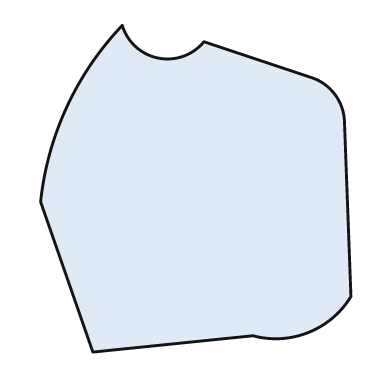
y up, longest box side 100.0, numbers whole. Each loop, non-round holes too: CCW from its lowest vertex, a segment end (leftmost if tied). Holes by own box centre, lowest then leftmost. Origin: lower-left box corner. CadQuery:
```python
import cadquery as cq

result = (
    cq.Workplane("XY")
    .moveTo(16.0, 0.0)
    .lineTo(65.0, 5.0)
    .threePointArc((82.0, 6.0), (95.0, 17.0))
    .lineTo(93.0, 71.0)
    .threePointArc((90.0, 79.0), (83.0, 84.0))
    .lineTo(50.0, 95.0)
    .threePointArc((36.0, 90.0), (25.0, 100.0))
    .threePointArc((8.0, 75.0), (0.0, 46.0))
    .close()
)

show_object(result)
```